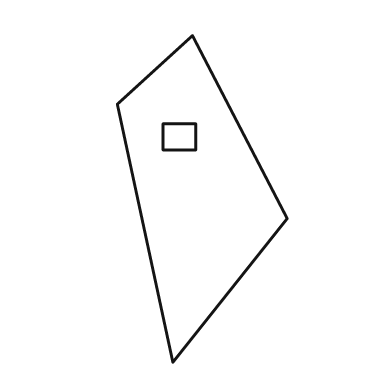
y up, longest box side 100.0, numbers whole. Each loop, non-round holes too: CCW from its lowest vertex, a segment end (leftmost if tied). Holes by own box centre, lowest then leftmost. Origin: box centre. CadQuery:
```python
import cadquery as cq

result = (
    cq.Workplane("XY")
    .moveTo(-9.0, -50.0)
    .lineTo(26.0, -6.0)
    .lineTo(-3.0, 50.0)
    .lineTo(-26.0, 29.0)
    .close()
    .moveTo(-12.0, 15.0)
    .lineTo(-2.0, 15.0)
    .lineTo(-2.0, 23.0)
    .lineTo(-12.0, 23.0)
    .close()
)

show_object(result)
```